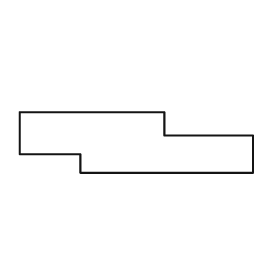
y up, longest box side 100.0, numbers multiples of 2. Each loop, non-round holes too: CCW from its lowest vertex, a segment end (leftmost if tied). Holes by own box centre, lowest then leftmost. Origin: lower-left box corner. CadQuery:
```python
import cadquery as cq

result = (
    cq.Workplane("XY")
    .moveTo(26.0, 0.0)
    .lineTo(100.0, 0.0)
    .lineTo(100.0, 16.0)
    .lineTo(62.0, 16.0)
    .lineTo(62.0, 26.0)
    .lineTo(0.0, 26.0)
    .lineTo(0.0, 8.0)
    .lineTo(26.0, 8.0)
    .close()
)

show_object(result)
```